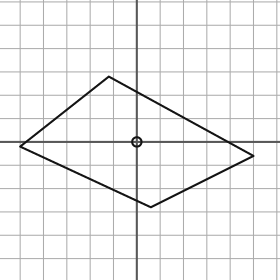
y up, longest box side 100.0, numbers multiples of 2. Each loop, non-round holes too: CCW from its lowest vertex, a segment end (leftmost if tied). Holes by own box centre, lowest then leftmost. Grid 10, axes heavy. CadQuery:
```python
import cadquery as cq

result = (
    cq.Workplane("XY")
    .moveTo(6.0, -28.0)
    .lineTo(50.0, -6.0)
    .lineTo(-12.0, 28.0)
    .lineTo(-50.0, -2.0)
    .close()
    .moveTo(0.0, 0.0)
    .circle(2.0)
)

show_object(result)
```